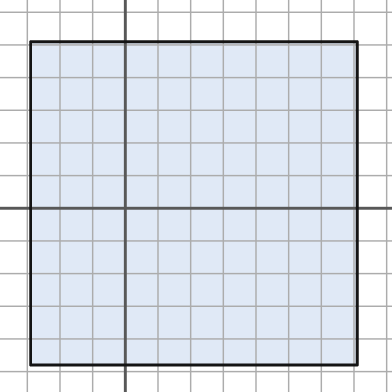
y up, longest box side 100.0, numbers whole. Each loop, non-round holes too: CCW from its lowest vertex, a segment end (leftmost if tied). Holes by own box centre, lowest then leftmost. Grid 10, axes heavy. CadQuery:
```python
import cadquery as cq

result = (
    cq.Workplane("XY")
    .moveTo(-29.0, -48.0)
    .lineTo(71.0, -48.0)
    .lineTo(71.0, 51.0)
    .lineTo(-29.0, 51.0)
    .close()
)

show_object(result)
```